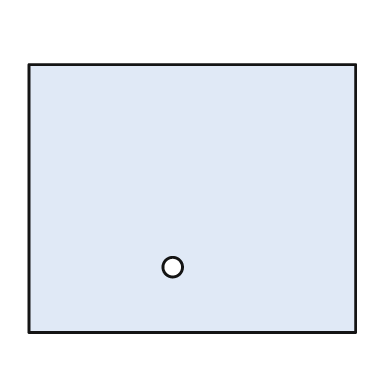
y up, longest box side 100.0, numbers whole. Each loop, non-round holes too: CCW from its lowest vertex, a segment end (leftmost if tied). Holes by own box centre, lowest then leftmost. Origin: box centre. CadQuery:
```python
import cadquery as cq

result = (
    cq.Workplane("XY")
    .moveTo(-50.0, -41.0)
    .lineTo(50.0, -41.0)
    .lineTo(50.0, 41.0)
    .lineTo(-50.0, 41.0)
    .close()
    .moveTo(-6.0, -21.0)
    .circle(3.0)
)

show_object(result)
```